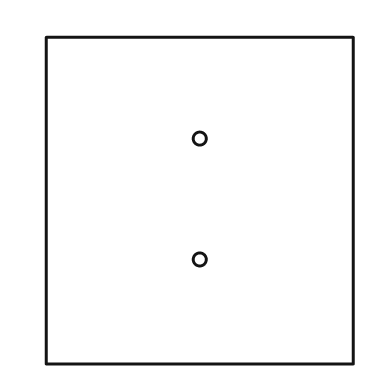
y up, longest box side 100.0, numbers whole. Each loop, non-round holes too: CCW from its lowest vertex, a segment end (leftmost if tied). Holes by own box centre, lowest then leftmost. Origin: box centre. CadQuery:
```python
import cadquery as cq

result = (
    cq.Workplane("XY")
    .moveTo(-47.0, -50.0)
    .lineTo(47.0, -50.0)
    .lineTo(47.0, 50.0)
    .lineTo(-47.0, 50.0)
    .close()
    .moveTo(0.0, -18.0)
    .circle(2.0)
    .moveTo(0.0, 19.0)
    .circle(2.0)
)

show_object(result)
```